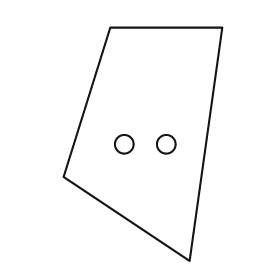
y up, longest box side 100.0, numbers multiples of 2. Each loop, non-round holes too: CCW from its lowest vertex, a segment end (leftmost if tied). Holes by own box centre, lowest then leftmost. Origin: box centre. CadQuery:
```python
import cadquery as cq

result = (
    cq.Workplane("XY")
    .moveTo(20.0, -50.0)
    .lineTo(34.0, 50.0)
    .lineTo(-14.0, 50.0)
    .lineTo(-34.0, -14.0)
    .close()
    .moveTo(-8.0, 0.0)
    .circle(4.0)
    .moveTo(10.0, 0.0)
    .circle(4.0)
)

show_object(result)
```